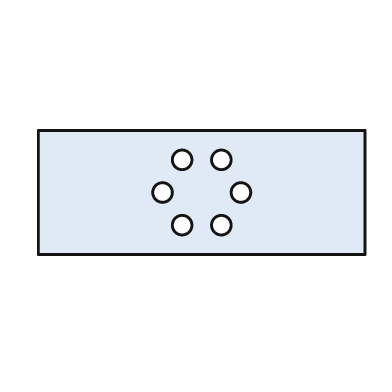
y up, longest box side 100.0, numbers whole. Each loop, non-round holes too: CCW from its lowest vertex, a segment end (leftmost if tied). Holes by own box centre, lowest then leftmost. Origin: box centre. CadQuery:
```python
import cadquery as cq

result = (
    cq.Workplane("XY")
    .moveTo(-50.0, -19.0)
    .lineTo(50.0, -19.0)
    .lineTo(50.0, 19.0)
    .lineTo(-50.0, 19.0)
    .close()
    .moveTo(-6.0, -10.0)
    .circle(3.0)
    .moveTo(6.0, -10.0)
    .circle(3.0)
    .moveTo(-12.0, 0.0)
    .circle(3.0)
    .moveTo(12.0, 0.0)
    .circle(3.0)
    .moveTo(-6.0, 10.0)
    .circle(3.0)
    .moveTo(6.0, 10.0)
    .circle(3.0)
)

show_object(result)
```